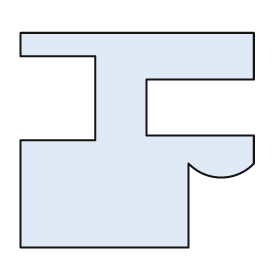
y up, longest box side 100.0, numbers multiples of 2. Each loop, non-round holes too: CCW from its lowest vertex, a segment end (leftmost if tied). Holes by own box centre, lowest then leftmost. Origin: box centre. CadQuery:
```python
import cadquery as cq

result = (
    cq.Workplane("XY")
    .moveTo(-50.0, -46.0)
    .lineTo(22.0, -46.0)
    .lineTo(22.0, -10.0)
    .threePointArc((36.0, -16.0), (50.0, -10.0))
    .lineTo(50.0, 2.0)
    .lineTo(4.0, 2.0)
    .lineTo(4.0, 26.0)
    .lineTo(50.0, 26.0)
    .lineTo(50.0, 46.0)
    .lineTo(-50.0, 46.0)
    .lineTo(-50.0, 36.0)
    .lineTo(-18.0, 36.0)
    .lineTo(-18.0, 0.0)
    .lineTo(-50.0, 0.0)
    .close()
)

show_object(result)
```